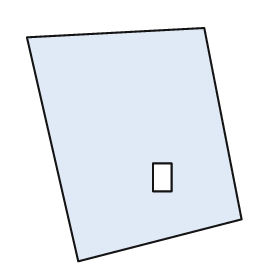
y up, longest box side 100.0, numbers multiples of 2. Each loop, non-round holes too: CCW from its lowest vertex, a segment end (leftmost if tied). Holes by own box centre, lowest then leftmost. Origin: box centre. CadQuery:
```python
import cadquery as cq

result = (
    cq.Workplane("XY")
    .moveTo(-24.0, -50.0)
    .lineTo(46.0, -32.0)
    .lineTo(30.0, 50.0)
    .lineTo(-46.0, 46.0)
    .close()
    .moveTo(8.0, -20.0)
    .lineTo(16.0, -20.0)
    .lineTo(16.0, -8.0)
    .lineTo(8.0, -8.0)
    .close()
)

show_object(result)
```